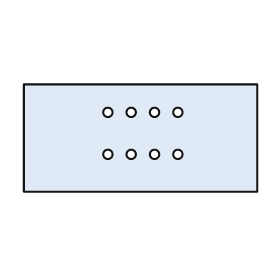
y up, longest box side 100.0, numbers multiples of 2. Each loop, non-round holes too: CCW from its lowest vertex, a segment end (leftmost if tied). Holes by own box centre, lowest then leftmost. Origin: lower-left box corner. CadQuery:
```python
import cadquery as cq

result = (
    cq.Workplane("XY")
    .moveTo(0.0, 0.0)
    .lineTo(100.0, 0.0)
    .lineTo(100.0, 46.0)
    .lineTo(0.0, 46.0)
    .close()
    .moveTo(36.0, 16.0)
    .circle(2.0)
    .moveTo(46.0, 16.0)
    .circle(2.0)
    .moveTo(56.0, 16.0)
    .circle(2.0)
    .moveTo(66.0, 16.0)
    .circle(2.0)
    .moveTo(36.0, 34.0)
    .circle(2.0)
    .moveTo(46.0, 34.0)
    .circle(2.0)
    .moveTo(56.0, 34.0)
    .circle(2.0)
    .moveTo(66.0, 34.0)
    .circle(2.0)
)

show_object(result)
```